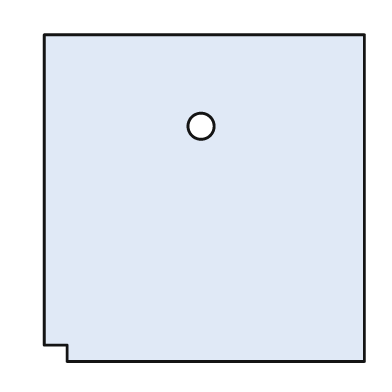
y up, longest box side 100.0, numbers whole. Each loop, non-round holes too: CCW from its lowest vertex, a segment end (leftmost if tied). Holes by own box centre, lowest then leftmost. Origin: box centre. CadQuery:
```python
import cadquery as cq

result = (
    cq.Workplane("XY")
    .moveTo(-42.0, -50.0)
    .lineTo(49.0, -50.0)
    .lineTo(49.0, 50.0)
    .lineTo(-49.0, 50.0)
    .lineTo(-49.0, -45.0)
    .lineTo(-42.0, -45.0)
    .close()
    .moveTo(-1.0, 22.0)
    .circle(4.0)
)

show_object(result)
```